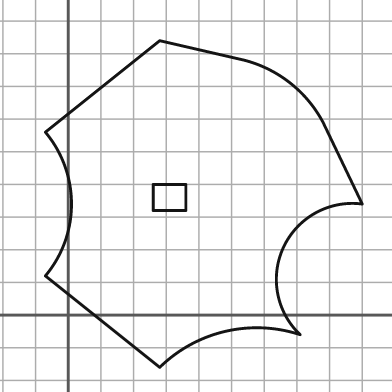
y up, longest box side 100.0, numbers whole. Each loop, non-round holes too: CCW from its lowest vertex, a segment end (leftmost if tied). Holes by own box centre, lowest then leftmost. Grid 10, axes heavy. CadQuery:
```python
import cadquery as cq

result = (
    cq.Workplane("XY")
    .moveTo(28.0, -16.0)
    .threePointArc((48.0, -5.0), (71.0, -6.0))
    .threePointArc((66.0, 21.0), (90.0, 34.0))
    .lineTo(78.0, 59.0)
    .threePointArc((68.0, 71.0), (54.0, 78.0))
    .lineTo(28.0, 84.0)
    .lineTo(-7.0, 56.0)
    .threePointArc((1.0, 34.0), (-7.0, 12.0))
    .close()
    .moveTo(26.0, 32.0)
    .lineTo(36.0, 32.0)
    .lineTo(36.0, 40.0)
    .lineTo(26.0, 40.0)
    .close()
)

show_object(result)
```